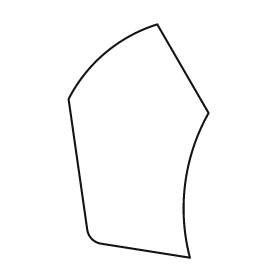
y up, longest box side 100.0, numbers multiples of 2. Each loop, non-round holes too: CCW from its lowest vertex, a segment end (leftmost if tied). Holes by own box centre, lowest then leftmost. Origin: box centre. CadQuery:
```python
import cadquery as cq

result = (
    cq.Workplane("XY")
    .moveTo(22.0, -50.0)
    .threePointArc((20.0, -18.0), (30.0, 12.0))
    .lineTo(8.0, 50.0)
    .threePointArc((-14.0, 38.0), (-30.0, 18.0))
    .lineTo(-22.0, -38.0)
    .threePointArc((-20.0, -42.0), (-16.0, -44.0))
    .close()
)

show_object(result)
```